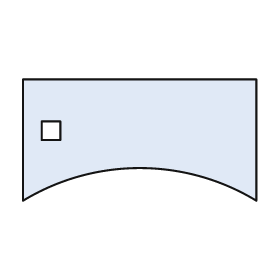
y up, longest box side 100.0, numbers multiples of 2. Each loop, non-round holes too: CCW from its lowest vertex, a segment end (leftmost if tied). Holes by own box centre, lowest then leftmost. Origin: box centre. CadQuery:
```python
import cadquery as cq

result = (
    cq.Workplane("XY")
    .moveTo(-50.0, -26.0)
    .threePointArc((0.0, -12.0), (50.0, -26.0))
    .lineTo(50.0, 26.0)
    .lineTo(-50.0, 26.0)
    .close()
    .moveTo(-42.0, 0.0)
    .lineTo(-34.0, 0.0)
    .lineTo(-34.0, 8.0)
    .lineTo(-42.0, 8.0)
    .close()
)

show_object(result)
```